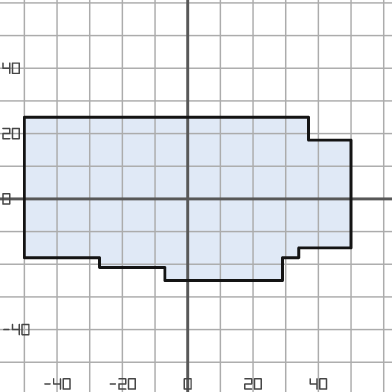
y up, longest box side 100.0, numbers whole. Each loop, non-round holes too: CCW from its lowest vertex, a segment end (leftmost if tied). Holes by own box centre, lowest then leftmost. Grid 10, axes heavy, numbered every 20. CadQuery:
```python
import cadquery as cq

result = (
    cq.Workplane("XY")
    .moveTo(-7.0, -25.0)
    .lineTo(29.0, -25.0)
    .lineTo(29.0, -18.0)
    .lineTo(34.0, -18.0)
    .lineTo(34.0, -15.0)
    .lineTo(50.0, -15.0)
    .lineTo(50.0, 18.0)
    .lineTo(37.0, 18.0)
    .lineTo(37.0, 25.0)
    .lineTo(-50.0, 25.0)
    .lineTo(-50.0, -18.0)
    .lineTo(-27.0, -18.0)
    .lineTo(-27.0, -21.0)
    .lineTo(-7.0, -21.0)
    .close()
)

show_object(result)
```